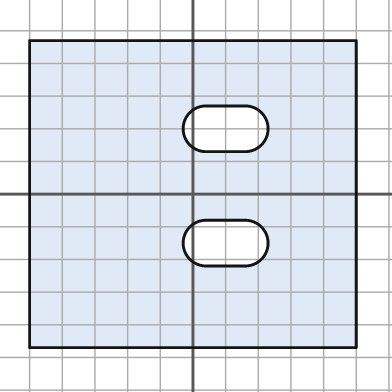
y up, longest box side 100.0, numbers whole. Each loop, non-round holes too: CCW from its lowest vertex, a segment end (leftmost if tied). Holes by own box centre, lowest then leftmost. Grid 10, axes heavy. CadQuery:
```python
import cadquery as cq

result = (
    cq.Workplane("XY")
    .moveTo(-50.0, -47.0)
    .lineTo(50.0, -47.0)
    .lineTo(50.0, 47.0)
    .lineTo(-50.0, 47.0)
    .close()
    .moveTo(4.0, -22.0)
    .lineTo(16.0, -22.0)
    .threePointArc((23.0, -15.0), (16.0, -8.0))
    .lineTo(4.0, -8.0)
    .threePointArc((-3.0, -15.0), (4.0, -22.0))
    .close()
    .moveTo(4.0, 13.0)
    .lineTo(16.0, 13.0)
    .threePointArc((23.0, 20.0), (16.0, 27.0))
    .lineTo(4.0, 27.0)
    .threePointArc((-3.0, 20.0), (4.0, 13.0))
    .close()
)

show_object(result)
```